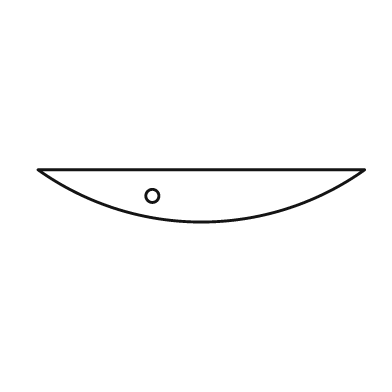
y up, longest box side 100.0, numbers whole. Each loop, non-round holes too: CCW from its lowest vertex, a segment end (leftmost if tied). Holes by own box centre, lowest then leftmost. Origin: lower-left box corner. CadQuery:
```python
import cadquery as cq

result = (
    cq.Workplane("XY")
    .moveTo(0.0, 16.0)
    .threePointArc((50.0, 0.0), (100.0, 16.0))
    .close()
    .moveTo(35.0, 8.0)
    .circle(2.0)
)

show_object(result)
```